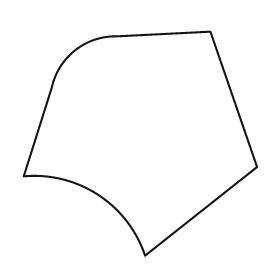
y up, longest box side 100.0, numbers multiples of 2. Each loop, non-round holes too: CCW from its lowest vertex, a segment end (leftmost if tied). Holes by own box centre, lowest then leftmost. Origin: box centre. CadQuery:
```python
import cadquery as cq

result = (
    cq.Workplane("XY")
    .moveTo(2.0, -48.0)
    .lineTo(50.0, -10.0)
    .lineTo(30.0, 48.0)
    .lineTo(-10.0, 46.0)
    .threePointArc((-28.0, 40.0), (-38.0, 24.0))
    .lineTo(-50.0, -14.0)
    .threePointArc((-18.0, -22.0), (2.0, -48.0))
    .close()
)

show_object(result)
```